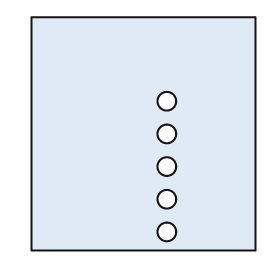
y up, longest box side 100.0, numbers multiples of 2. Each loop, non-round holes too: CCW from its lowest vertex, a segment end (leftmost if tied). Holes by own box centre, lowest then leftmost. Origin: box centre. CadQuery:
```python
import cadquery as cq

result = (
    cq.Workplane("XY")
    .moveTo(-48.0, -50.0)
    .lineTo(48.0, -50.0)
    .lineTo(48.0, 50.0)
    .lineTo(-48.0, 50.0)
    .close()
    .moveTo(10.0, -42.0)
    .circle(4.0)
    .moveTo(10.0, -28.0)
    .circle(4.0)
    .moveTo(10.0, -14.0)
    .circle(4.0)
    .moveTo(10.0, 0.0)
    .circle(4.0)
    .moveTo(10.0, 14.0)
    .circle(4.0)
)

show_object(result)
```